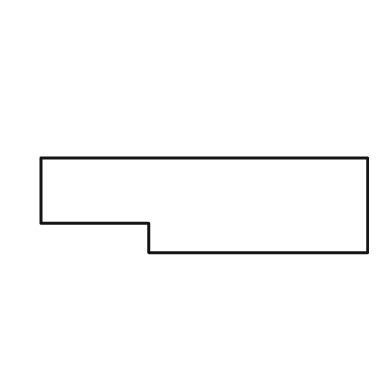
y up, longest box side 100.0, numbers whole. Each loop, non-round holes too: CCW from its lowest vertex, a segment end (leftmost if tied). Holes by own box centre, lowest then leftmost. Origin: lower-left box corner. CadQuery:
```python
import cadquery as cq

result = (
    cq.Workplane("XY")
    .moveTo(33.0, 0.0)
    .lineTo(100.0, 0.0)
    .lineTo(100.0, 29.0)
    .lineTo(0.0, 29.0)
    .lineTo(0.0, 9.0)
    .lineTo(33.0, 9.0)
    .close()
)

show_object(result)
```